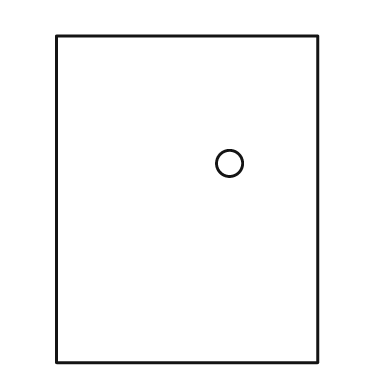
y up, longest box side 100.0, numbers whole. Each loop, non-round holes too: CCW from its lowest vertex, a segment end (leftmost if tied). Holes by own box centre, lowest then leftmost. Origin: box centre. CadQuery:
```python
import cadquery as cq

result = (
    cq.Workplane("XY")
    .moveTo(-40.0, -50.0)
    .lineTo(40.0, -50.0)
    .lineTo(40.0, 50.0)
    .lineTo(-40.0, 50.0)
    .close()
    .moveTo(13.0, 11.0)
    .circle(4.0)
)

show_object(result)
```